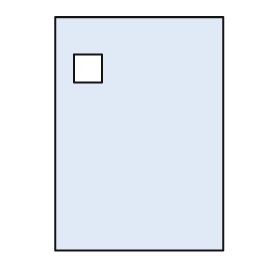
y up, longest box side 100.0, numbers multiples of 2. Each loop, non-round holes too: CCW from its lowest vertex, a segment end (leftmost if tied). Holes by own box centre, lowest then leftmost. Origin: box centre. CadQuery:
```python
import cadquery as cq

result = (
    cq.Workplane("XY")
    .moveTo(-36.0, -50.0)
    .lineTo(36.0, -50.0)
    .lineTo(36.0, 50.0)
    .lineTo(-36.0, 50.0)
    .close()
    .moveTo(-28.0, 22.0)
    .lineTo(-16.0, 22.0)
    .lineTo(-16.0, 34.0)
    .lineTo(-28.0, 34.0)
    .close()
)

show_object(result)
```